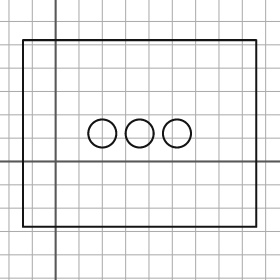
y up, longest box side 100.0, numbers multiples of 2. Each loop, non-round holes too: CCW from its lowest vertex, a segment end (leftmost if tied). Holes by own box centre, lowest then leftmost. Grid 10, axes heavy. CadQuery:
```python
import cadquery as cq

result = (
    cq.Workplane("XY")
    .moveTo(-14.0, -28.0)
    .lineTo(86.0, -28.0)
    .lineTo(86.0, 52.0)
    .lineTo(-14.0, 52.0)
    .close()
    .moveTo(20.0, 12.0)
    .circle(6.0)
    .moveTo(36.0, 12.0)
    .circle(6.0)
    .moveTo(52.0, 12.0)
    .circle(6.0)
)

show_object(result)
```